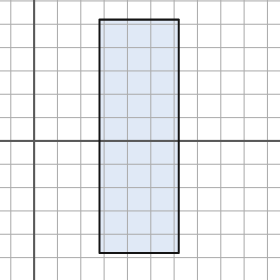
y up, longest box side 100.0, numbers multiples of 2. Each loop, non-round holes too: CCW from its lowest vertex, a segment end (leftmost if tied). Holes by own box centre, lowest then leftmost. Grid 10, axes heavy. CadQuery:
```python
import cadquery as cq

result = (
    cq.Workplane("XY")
    .moveTo(28.0, -48.0)
    .lineTo(62.0, -48.0)
    .lineTo(62.0, 52.0)
    .lineTo(28.0, 52.0)
    .close()
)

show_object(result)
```